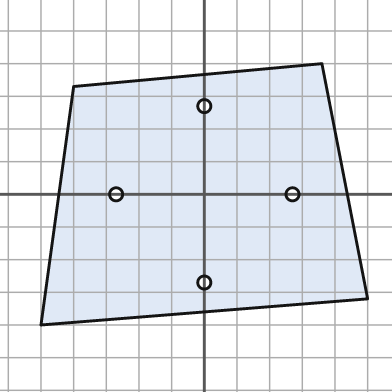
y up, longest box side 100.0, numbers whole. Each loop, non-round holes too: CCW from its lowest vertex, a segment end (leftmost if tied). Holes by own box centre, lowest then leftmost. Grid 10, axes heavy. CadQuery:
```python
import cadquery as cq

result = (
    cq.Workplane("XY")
    .moveTo(-50.0, -40.0)
    .lineTo(50.0, -32.0)
    .lineTo(36.0, 40.0)
    .lineTo(-40.0, 33.0)
    .close()
    .moveTo(0.0, -27.0)
    .circle(2.0)
    .moveTo(-27.0, 0.0)
    .circle(2.0)
    .moveTo(27.0, 0.0)
    .circle(2.0)
    .moveTo(0.0, 27.0)
    .circle(2.0)
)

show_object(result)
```